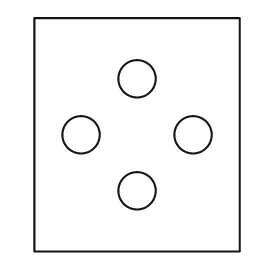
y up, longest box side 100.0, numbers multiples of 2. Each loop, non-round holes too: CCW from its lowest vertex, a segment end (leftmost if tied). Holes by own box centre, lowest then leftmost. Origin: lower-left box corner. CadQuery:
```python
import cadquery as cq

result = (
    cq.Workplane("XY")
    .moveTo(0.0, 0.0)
    .lineTo(88.0, 0.0)
    .lineTo(88.0, 100.0)
    .lineTo(0.0, 100.0)
    .close()
    .moveTo(44.0, 26.0)
    .circle(8.0)
    .moveTo(20.0, 50.0)
    .circle(8.0)
    .moveTo(68.0, 50.0)
    .circle(8.0)
    .moveTo(44.0, 74.0)
    .circle(8.0)
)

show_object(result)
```